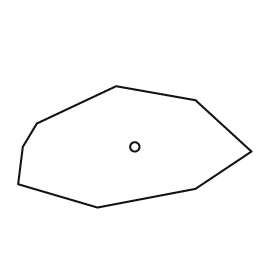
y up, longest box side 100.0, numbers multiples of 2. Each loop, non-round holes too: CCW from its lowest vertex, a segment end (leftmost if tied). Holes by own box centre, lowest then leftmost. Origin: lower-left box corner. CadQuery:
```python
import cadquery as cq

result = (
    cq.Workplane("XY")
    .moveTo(34.0, 0.0)
    .lineTo(76.0, 8.0)
    .lineTo(100.0, 24.0)
    .lineTo(76.0, 46.0)
    .lineTo(42.0, 52.0)
    .lineTo(8.0, 36.0)
    .lineTo(2.0, 26.0)
    .lineTo(0.0, 10.0)
    .close()
    .moveTo(50.0, 26.0)
    .circle(2.0)
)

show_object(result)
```